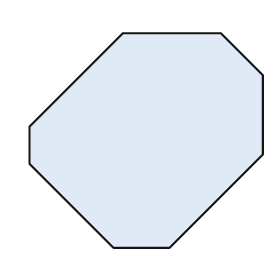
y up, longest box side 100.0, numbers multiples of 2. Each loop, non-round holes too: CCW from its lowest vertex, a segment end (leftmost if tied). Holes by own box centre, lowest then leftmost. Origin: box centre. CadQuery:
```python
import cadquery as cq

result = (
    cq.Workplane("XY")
    .moveTo(-14.0, -46.0)
    .lineTo(10.0, -46.0)
    .lineTo(50.0, -6.0)
    .lineTo(50.0, 28.0)
    .lineTo(32.0, 46.0)
    .lineTo(-10.0, 46.0)
    .lineTo(-50.0, 6.0)
    .lineTo(-50.0, -10.0)
    .close()
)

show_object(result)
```